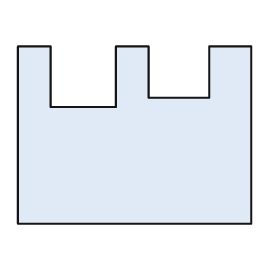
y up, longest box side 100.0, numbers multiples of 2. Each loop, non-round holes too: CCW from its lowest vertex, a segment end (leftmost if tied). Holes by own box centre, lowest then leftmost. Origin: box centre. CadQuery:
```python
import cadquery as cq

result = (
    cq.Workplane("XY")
    .moveTo(-50.0, -38.0)
    .lineTo(50.0, -38.0)
    .lineTo(50.0, 38.0)
    .lineTo(32.0, 38.0)
    .lineTo(32.0, 16.0)
    .lineTo(6.0, 16.0)
    .lineTo(6.0, 38.0)
    .lineTo(-8.0, 38.0)
    .lineTo(-8.0, 12.0)
    .lineTo(-36.0, 12.0)
    .lineTo(-36.0, 38.0)
    .lineTo(-50.0, 38.0)
    .close()
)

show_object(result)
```